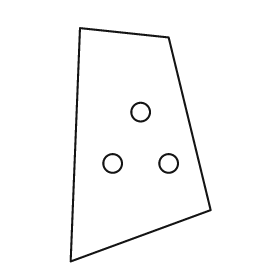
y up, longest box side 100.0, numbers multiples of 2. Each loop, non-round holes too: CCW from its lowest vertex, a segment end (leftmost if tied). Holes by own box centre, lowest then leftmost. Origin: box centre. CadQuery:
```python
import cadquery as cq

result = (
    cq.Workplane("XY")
    .moveTo(-30.0, -50.0)
    .lineTo(30.0, -28.0)
    .lineTo(12.0, 46.0)
    .lineTo(-26.0, 50.0)
    .close()
    .moveTo(-12.0, -8.0)
    .circle(4.0)
    .moveTo(12.0, -8.0)
    .circle(4.0)
    .moveTo(0.0, 14.0)
    .circle(4.0)
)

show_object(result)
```